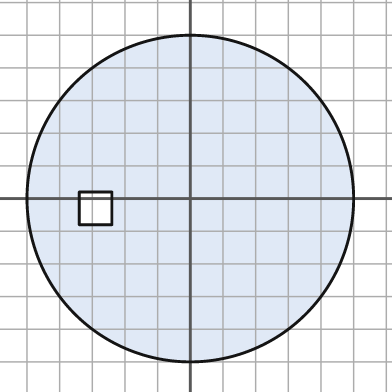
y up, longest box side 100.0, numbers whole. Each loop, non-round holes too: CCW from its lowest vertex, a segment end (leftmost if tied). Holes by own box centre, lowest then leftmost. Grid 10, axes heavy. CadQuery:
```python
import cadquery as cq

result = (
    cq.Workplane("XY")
    .moveTo(0.0, 0.0)
    .circle(50.0)
    .moveTo(-34.0, -8.0)
    .lineTo(-24.0, -8.0)
    .lineTo(-24.0, 2.0)
    .lineTo(-34.0, 2.0)
    .close()
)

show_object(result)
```